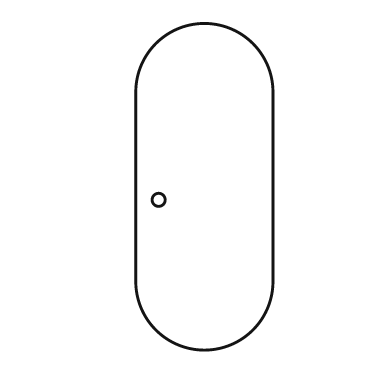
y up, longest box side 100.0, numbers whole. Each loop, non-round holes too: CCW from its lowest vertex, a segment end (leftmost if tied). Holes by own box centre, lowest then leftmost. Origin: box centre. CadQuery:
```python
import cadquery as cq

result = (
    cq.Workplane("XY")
    .moveTo(-21.0, -29.0)
    .threePointArc((0.0, -50.0), (21.0, -29.0))
    .lineTo(21.0, 29.0)
    .threePointArc((0.0, 50.0), (-21.0, 29.0))
    .close()
    .moveTo(-14.0, -4.0)
    .circle(2.0)
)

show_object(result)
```